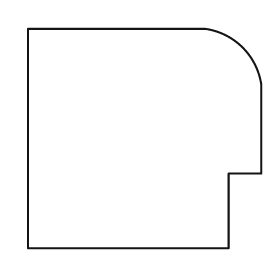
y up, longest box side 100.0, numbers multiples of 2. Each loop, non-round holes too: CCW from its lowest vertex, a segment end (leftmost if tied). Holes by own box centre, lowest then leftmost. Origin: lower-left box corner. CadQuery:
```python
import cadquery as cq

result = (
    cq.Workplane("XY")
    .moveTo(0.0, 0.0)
    .lineTo(86.0, 0.0)
    .lineTo(86.0, 32.0)
    .lineTo(100.0, 32.0)
    .lineTo(100.0, 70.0)
    .threePointArc((92.0, 86.0), (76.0, 94.0))
    .lineTo(0.0, 94.0)
    .close()
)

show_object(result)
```